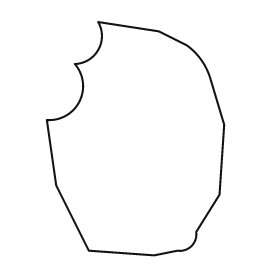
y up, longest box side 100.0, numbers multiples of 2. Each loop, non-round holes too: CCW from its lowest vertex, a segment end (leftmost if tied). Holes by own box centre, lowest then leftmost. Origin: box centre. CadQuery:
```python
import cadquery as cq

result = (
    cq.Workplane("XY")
    .moveTo(8.0, -50.0)
    .lineTo(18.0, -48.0)
    .threePointArc((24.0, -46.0), (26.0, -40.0))
    .lineTo(36.0, -24.0)
    .lineTo(38.0, 6.0)
    .lineTo(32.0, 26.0)
    .threePointArc((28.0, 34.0), (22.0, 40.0))
    .lineTo(10.0, 46.0)
    .lineTo(-16.0, 50.0)
    .threePointArc((-16.0, 38.0), (-26.0, 32.0))
    .threePointArc((-24.0, 16.0), (-38.0, 8.0))
    .lineTo(-34.0, -20.0)
    .lineTo(-20.0, -48.0)
    .close()
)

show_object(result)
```